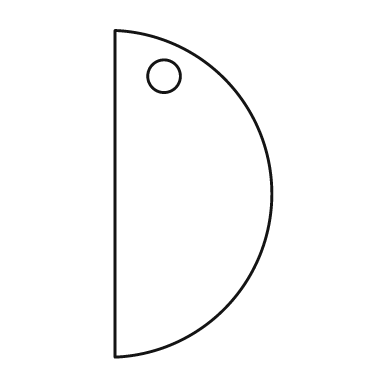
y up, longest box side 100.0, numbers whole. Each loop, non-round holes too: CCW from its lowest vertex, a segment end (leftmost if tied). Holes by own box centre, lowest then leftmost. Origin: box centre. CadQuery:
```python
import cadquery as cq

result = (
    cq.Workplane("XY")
    .moveTo(-24.0, -50.0)
    .threePointArc((24.0, 0.0), (-24.0, 50.0))
    .close()
    .moveTo(-9.0, 36.0)
    .circle(5.0)
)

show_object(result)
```